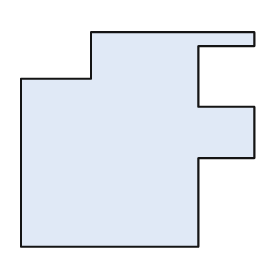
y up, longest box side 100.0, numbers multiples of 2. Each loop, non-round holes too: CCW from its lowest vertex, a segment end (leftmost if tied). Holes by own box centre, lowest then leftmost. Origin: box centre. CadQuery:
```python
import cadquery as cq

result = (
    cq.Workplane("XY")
    .moveTo(-50.0, -46.0)
    .lineTo(26.0, -46.0)
    .lineTo(26.0, -8.0)
    .lineTo(50.0, -8.0)
    .lineTo(50.0, 14.0)
    .lineTo(26.0, 14.0)
    .lineTo(26.0, 40.0)
    .lineTo(50.0, 40.0)
    .lineTo(50.0, 46.0)
    .lineTo(-20.0, 46.0)
    .lineTo(-20.0, 26.0)
    .lineTo(-50.0, 26.0)
    .close()
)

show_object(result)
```